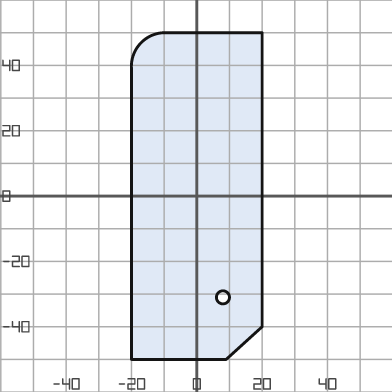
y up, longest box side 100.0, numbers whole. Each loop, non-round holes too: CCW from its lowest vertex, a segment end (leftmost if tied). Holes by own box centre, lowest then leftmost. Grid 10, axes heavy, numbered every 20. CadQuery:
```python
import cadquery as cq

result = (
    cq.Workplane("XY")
    .moveTo(-20.0, -50.0)
    .lineTo(9.0, -50.0)
    .lineTo(20.0, -40.0)
    .lineTo(20.0, 50.0)
    .lineTo(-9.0, 50.0)
    .threePointArc((-17.0, 47.0), (-20.0, 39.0))
    .close()
    .moveTo(8.0, -31.0)
    .circle(2.0)
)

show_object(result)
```